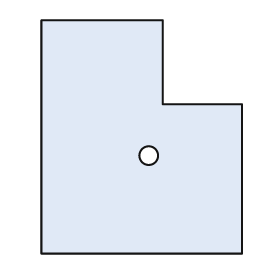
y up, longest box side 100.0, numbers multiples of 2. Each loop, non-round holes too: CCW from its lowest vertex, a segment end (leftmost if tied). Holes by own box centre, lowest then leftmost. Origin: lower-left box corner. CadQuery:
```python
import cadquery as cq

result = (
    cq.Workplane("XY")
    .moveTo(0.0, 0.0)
    .lineTo(86.0, 0.0)
    .lineTo(86.0, 64.0)
    .lineTo(52.0, 64.0)
    .lineTo(52.0, 100.0)
    .lineTo(0.0, 100.0)
    .close()
    .moveTo(46.0, 42.0)
    .circle(4.0)
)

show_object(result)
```